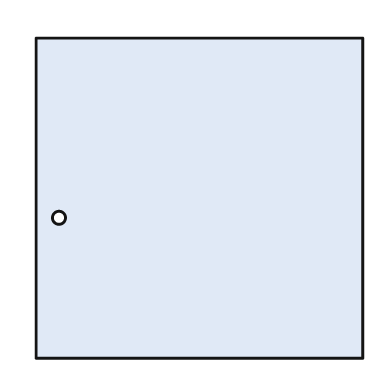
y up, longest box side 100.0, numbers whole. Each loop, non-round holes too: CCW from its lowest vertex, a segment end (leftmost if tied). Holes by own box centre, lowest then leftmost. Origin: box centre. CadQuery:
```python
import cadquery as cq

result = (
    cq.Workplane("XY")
    .moveTo(-50.0, -49.0)
    .lineTo(50.0, -49.0)
    .lineTo(50.0, 49.0)
    .lineTo(-50.0, 49.0)
    .close()
    .moveTo(-43.0, -6.0)
    .circle(2.0)
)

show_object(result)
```